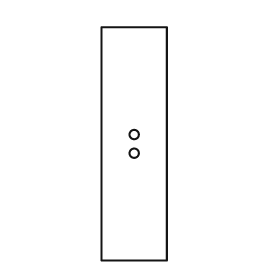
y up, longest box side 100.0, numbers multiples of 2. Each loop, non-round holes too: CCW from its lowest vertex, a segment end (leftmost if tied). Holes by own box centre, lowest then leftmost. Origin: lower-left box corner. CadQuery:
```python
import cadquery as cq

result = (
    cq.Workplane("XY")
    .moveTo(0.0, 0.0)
    .lineTo(28.0, 0.0)
    .lineTo(28.0, 100.0)
    .lineTo(0.0, 100.0)
    .close()
    .moveTo(14.0, 46.0)
    .circle(2.0)
    .moveTo(14.0, 54.0)
    .circle(2.0)
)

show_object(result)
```